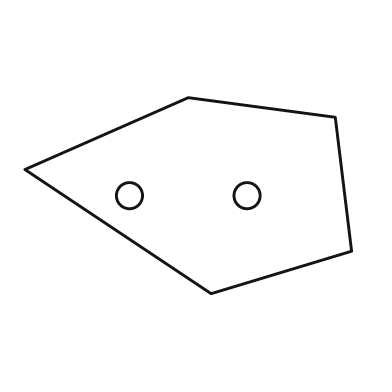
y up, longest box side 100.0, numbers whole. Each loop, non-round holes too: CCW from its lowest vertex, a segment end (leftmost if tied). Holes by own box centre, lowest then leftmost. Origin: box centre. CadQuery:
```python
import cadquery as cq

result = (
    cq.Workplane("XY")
    .moveTo(7.0, -30.0)
    .lineTo(50.0, -17.0)
    .lineTo(45.0, 24.0)
    .lineTo(0.0, 30.0)
    .lineTo(-50.0, 8.0)
    .close()
    .moveTo(-18.0, 0.0)
    .circle(4.0)
    .moveTo(18.0, 0.0)
    .circle(4.0)
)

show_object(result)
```